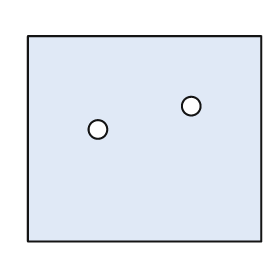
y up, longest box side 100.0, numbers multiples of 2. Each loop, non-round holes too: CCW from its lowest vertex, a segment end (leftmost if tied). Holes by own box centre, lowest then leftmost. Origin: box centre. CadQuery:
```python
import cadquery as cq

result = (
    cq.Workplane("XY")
    .moveTo(-50.0, -44.0)
    .lineTo(50.0, -44.0)
    .lineTo(50.0, 44.0)
    .lineTo(-50.0, 44.0)
    .close()
    .moveTo(-20.0, 4.0)
    .circle(4.0)
    .moveTo(20.0, 14.0)
    .circle(4.0)
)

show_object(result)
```